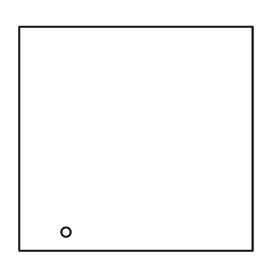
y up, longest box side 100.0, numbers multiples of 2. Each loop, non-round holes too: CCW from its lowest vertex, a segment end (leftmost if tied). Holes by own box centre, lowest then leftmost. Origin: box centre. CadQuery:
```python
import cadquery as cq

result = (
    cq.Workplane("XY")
    .moveTo(-50.0, -48.0)
    .lineTo(50.0, -48.0)
    .lineTo(50.0, 48.0)
    .lineTo(-50.0, 48.0)
    .close()
    .moveTo(-30.0, -40.0)
    .circle(2.0)
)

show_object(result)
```